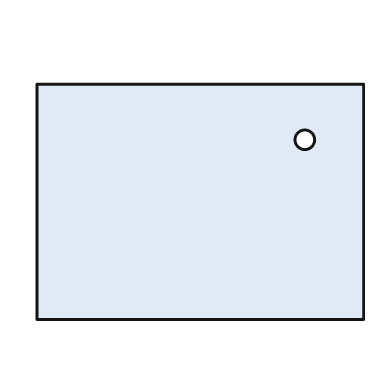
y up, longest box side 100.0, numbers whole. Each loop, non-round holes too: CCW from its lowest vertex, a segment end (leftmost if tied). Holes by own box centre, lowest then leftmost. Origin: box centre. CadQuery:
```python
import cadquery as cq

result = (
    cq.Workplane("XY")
    .moveTo(-50.0, -36.0)
    .lineTo(50.0, -36.0)
    .lineTo(50.0, 36.0)
    .lineTo(-50.0, 36.0)
    .close()
    .moveTo(32.0, 19.0)
    .circle(3.0)
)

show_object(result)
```